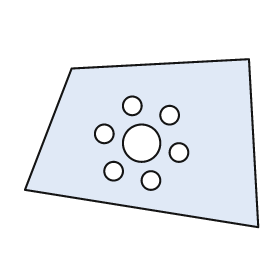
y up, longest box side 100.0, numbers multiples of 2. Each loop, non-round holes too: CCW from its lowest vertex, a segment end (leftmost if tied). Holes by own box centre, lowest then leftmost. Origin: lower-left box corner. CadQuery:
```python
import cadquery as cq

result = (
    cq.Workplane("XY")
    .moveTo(100.0, 0.0)
    .lineTo(96.0, 72.0)
    .lineTo(20.0, 68.0)
    .lineTo(0.0, 16.0)
    .close()
    .moveTo(54.0, 20.0)
    .circle(4.0)
    .moveTo(38.0, 24.0)
    .circle(4.0)
    .moveTo(66.0, 32.0)
    .circle(4.0)
    .moveTo(50.0, 36.0)
    .circle(8.0)
    .moveTo(34.0, 40.0)
    .circle(4.0)
    .moveTo(62.0, 48.0)
    .circle(4.0)
    .moveTo(46.0, 52.0)
    .circle(4.0)
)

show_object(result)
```